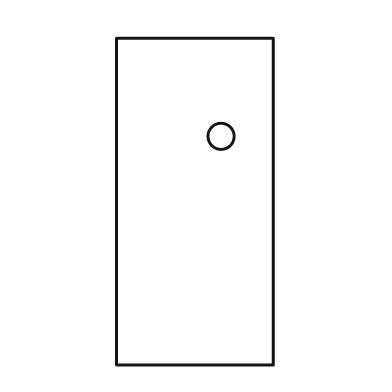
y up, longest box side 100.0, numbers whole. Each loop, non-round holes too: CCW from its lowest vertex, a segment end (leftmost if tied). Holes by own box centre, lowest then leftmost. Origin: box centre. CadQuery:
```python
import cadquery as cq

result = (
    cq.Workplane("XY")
    .moveTo(-24.0, -50.0)
    .lineTo(24.0, -50.0)
    .lineTo(24.0, 50.0)
    .lineTo(-24.0, 50.0)
    .close()
    .moveTo(8.0, 20.0)
    .circle(4.0)
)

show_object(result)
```